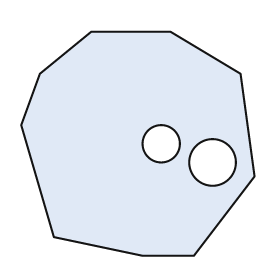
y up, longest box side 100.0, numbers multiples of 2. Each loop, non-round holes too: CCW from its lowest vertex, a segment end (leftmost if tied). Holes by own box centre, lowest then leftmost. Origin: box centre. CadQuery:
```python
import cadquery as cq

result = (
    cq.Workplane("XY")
    .moveTo(2.0, -48.0)
    .lineTo(24.0, -48.0)
    .lineTo(50.0, -14.0)
    .lineTo(44.0, 30.0)
    .lineTo(14.0, 48.0)
    .lineTo(-20.0, 48.0)
    .lineTo(-42.0, 30.0)
    .lineTo(-50.0, 8.0)
    .lineTo(-36.0, -40.0)
    .close()
    .moveTo(32.0, -8.0)
    .circle(10.0)
    .moveTo(10.0, 0.0)
    .circle(8.0)
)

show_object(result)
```